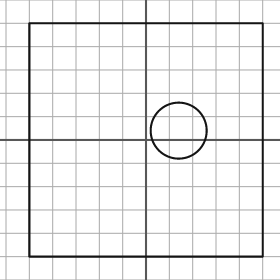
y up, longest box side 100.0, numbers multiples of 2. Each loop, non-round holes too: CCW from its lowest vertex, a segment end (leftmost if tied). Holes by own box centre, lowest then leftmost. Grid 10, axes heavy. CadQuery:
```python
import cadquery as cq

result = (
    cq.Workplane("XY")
    .moveTo(-50.0, -50.0)
    .lineTo(50.0, -50.0)
    .lineTo(50.0, 50.0)
    .lineTo(-50.0, 50.0)
    .close()
    .moveTo(14.0, 4.0)
    .circle(12.0)
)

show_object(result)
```